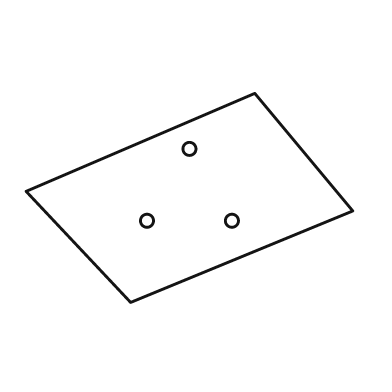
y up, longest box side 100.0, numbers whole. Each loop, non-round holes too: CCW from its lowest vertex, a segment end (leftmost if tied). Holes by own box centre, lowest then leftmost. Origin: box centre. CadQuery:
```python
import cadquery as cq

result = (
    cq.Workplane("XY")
    .moveTo(-18.0, -32.0)
    .lineTo(50.0, -4.0)
    .lineTo(20.0, 32.0)
    .lineTo(-50.0, 2.0)
    .close()
    .moveTo(-13.0, -7.0)
    .circle(2.0)
    .moveTo(13.0, -7.0)
    .circle(2.0)
    .moveTo(0.0, 15.0)
    .circle(2.0)
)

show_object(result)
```